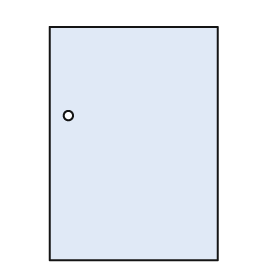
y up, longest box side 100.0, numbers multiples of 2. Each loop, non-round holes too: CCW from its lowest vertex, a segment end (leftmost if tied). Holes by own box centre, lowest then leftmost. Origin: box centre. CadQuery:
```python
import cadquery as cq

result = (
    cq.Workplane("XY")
    .moveTo(-36.0, -50.0)
    .lineTo(36.0, -50.0)
    .lineTo(36.0, 50.0)
    .lineTo(-36.0, 50.0)
    .close()
    .moveTo(-28.0, 12.0)
    .circle(2.0)
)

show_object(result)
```